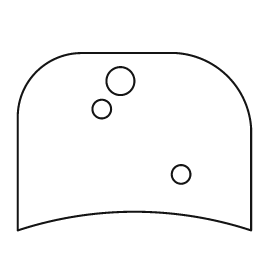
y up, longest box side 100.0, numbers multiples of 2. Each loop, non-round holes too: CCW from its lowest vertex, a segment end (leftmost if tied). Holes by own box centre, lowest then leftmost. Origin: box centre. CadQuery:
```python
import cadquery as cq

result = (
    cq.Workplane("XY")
    .moveTo(-50.0, -38.0)
    .threePointArc((0.0, -30.0), (50.0, -38.0))
    .lineTo(50.0, 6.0)
    .threePointArc((40.0, 28.0), (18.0, 38.0))
    .lineTo(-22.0, 38.0)
    .threePointArc((-42.0, 30.0), (-50.0, 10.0))
    .close()
    .moveTo(20.0, -14.0)
    .circle(4.0)
    .moveTo(-14.0, 14.0)
    .circle(4.0)
    .moveTo(-6.0, 26.0)
    .circle(6.0)
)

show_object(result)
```